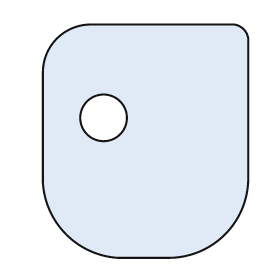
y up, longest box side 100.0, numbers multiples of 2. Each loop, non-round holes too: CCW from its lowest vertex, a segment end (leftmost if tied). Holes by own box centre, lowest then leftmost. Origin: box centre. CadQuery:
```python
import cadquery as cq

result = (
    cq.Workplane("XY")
    .moveTo(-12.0, -50.0)
    .lineTo(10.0, -50.0)
    .threePointArc((34.0, -40.0), (44.0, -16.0))
    .lineTo(44.0, 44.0)
    .threePointArc((42.0, 48.0), (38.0, 50.0))
    .lineTo(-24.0, 50.0)
    .threePointArc((-38.0, 44.0), (-44.0, 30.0))
    .lineTo(-44.0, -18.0)
    .threePointArc((-34.0, -40.0), (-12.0, -50.0))
    .close()
    .moveTo(-18.0, 10.0)
    .circle(10.0)
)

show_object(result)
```